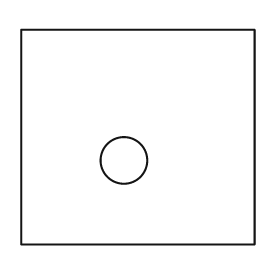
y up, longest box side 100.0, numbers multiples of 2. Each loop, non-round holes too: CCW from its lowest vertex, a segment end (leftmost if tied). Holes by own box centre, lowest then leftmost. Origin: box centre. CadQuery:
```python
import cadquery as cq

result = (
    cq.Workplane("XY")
    .moveTo(-50.0, -46.0)
    .lineTo(50.0, -46.0)
    .lineTo(50.0, 46.0)
    .lineTo(-50.0, 46.0)
    .close()
    .moveTo(-6.0, -10.0)
    .circle(10.0)
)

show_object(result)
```